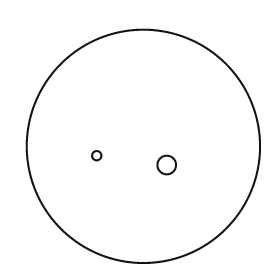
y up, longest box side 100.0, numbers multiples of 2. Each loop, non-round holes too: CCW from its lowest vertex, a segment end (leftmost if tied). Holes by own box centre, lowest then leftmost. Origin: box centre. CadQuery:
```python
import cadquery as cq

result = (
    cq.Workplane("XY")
    .moveTo(0.0, 0.0)
    .circle(50.0)
    .moveTo(10.0, -8.0)
    .circle(4.0)
    .moveTo(-20.0, -4.0)
    .circle(2.0)
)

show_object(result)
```